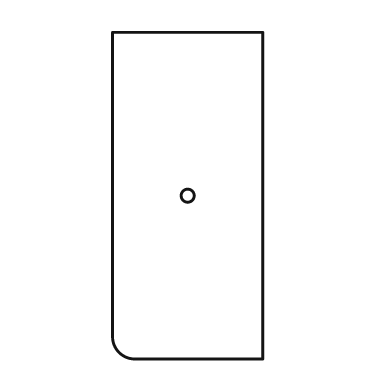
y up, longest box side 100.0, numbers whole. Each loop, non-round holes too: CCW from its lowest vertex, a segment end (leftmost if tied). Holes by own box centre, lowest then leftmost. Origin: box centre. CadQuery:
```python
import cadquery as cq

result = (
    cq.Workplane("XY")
    .moveTo(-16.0, -50.0)
    .lineTo(23.0, -50.0)
    .lineTo(23.0, 50.0)
    .lineTo(-23.0, 50.0)
    .lineTo(-23.0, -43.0)
    .threePointArc((-21.0, -48.0), (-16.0, -50.0))
    .close()
    .moveTo(0.0, 0.0)
    .circle(2.0)
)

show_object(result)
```